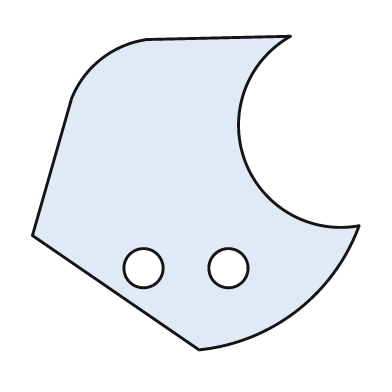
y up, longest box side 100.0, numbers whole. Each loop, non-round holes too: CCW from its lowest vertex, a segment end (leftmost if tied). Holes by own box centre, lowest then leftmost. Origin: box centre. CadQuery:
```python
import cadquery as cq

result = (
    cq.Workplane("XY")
    .moveTo(1.0, -48.0)
    .threePointArc((31.0, -36.0), (50.0, -10.0))
    .threePointArc((15.0, 10.0), (29.0, 48.0))
    .lineTo(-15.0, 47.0)
    .threePointArc((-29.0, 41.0), (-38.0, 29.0))
    .lineTo(-50.0, -13.0)
    .close()
    .moveTo(-16.0, -23.0)
    .circle(6.0)
    .moveTo(10.0, -23.0)
    .circle(6.0)
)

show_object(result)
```